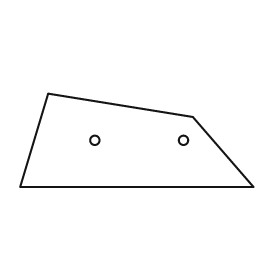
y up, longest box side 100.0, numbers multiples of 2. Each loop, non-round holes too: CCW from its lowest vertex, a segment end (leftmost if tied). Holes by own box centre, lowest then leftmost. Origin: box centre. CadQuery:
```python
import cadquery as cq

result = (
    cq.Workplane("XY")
    .moveTo(-50.0, -20.0)
    .lineTo(50.0, -20.0)
    .lineTo(24.0, 10.0)
    .lineTo(-38.0, 20.0)
    .close()
    .moveTo(-18.0, 0.0)
    .circle(2.0)
    .moveTo(20.0, 0.0)
    .circle(2.0)
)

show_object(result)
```